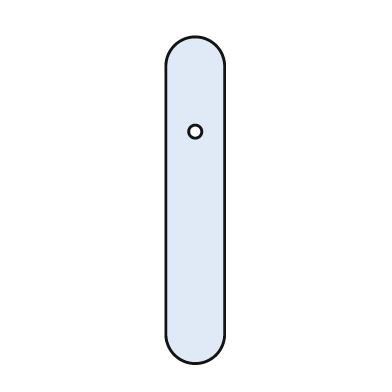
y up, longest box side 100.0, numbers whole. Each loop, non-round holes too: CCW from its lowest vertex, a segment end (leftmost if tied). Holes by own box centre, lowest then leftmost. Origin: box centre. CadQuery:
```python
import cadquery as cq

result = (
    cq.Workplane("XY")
    .moveTo(-9.0, -41.0)
    .threePointArc((0.0, -50.0), (9.0, -41.0))
    .lineTo(9.0, 41.0)
    .threePointArc((0.0, 50.0), (-9.0, 41.0))
    .close()
    .moveTo(0.0, 21.0)
    .circle(2.0)
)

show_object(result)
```